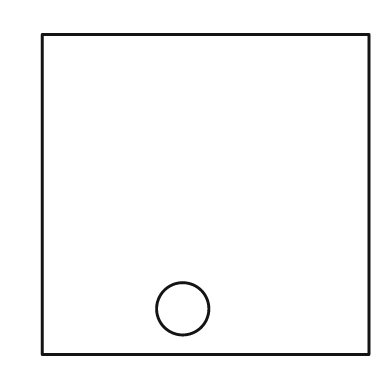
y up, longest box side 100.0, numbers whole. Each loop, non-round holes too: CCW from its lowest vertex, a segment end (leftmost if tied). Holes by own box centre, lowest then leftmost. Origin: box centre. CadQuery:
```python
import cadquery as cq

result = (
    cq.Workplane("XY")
    .moveTo(-50.0, -49.0)
    .lineTo(50.0, -49.0)
    .lineTo(50.0, 49.0)
    .lineTo(-50.0, 49.0)
    .close()
    .moveTo(-7.0, -35.0)
    .circle(8.0)
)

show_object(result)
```